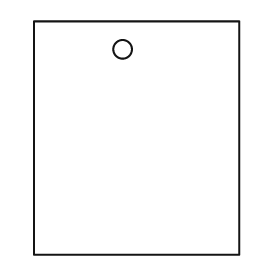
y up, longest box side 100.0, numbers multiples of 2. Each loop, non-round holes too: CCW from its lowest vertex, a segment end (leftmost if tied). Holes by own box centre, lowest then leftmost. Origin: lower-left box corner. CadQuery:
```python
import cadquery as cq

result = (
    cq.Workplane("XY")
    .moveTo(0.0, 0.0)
    .lineTo(88.0, 0.0)
    .lineTo(88.0, 100.0)
    .lineTo(0.0, 100.0)
    .close()
    .moveTo(38.0, 88.0)
    .circle(4.0)
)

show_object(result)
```